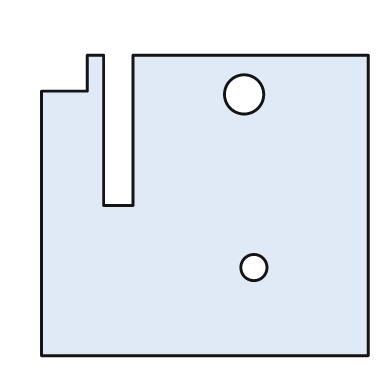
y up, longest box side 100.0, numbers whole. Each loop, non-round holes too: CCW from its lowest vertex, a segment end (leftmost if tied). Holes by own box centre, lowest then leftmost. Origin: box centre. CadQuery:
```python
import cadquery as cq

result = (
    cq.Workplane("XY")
    .moveTo(-50.0, -46.0)
    .lineTo(50.0, -46.0)
    .lineTo(50.0, 46.0)
    .lineTo(-22.0, 46.0)
    .lineTo(-22.0, 0.0)
    .lineTo(-31.0, 0.0)
    .lineTo(-31.0, 46.0)
    .lineTo(-36.0, 46.0)
    .lineTo(-36.0, 35.0)
    .lineTo(-50.0, 35.0)
    .close()
    .moveTo(15.0, -19.0)
    .circle(4.0)
    .moveTo(12.0, 34.0)
    .circle(6.0)
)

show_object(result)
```